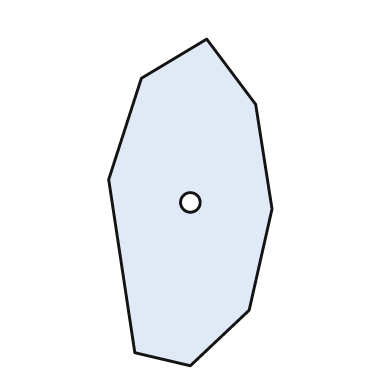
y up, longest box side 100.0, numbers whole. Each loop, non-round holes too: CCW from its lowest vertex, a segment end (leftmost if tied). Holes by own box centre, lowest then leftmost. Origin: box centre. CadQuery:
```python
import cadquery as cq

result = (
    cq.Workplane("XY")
    .moveTo(0.0, -50.0)
    .lineTo(18.0, -33.0)
    .lineTo(25.0, -2.0)
    .lineTo(20.0, 30.0)
    .lineTo(5.0, 50.0)
    .lineTo(-15.0, 38.0)
    .lineTo(-25.0, 7.0)
    .lineTo(-17.0, -46.0)
    .close()
    .moveTo(0.0, 0.0)
    .circle(3.0)
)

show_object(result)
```